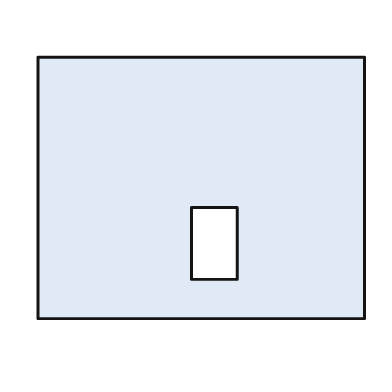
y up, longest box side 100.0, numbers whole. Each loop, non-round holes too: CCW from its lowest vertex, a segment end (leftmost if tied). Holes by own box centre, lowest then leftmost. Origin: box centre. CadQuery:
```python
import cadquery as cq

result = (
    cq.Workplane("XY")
    .moveTo(-50.0, -40.0)
    .lineTo(50.0, -40.0)
    .lineTo(50.0, 40.0)
    .lineTo(-50.0, 40.0)
    .close()
    .moveTo(-3.0, -28.0)
    .lineTo(11.0, -28.0)
    .lineTo(11.0, -6.0)
    .lineTo(-3.0, -6.0)
    .close()
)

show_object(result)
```